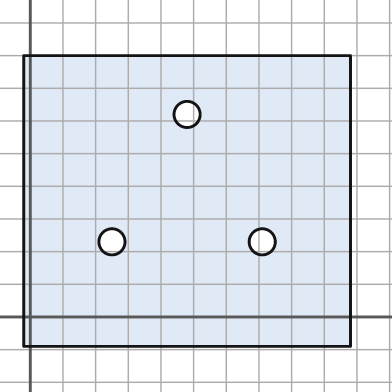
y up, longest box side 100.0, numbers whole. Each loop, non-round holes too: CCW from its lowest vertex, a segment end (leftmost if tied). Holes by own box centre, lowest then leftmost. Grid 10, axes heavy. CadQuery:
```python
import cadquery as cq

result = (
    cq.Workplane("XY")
    .moveTo(-2.0, -9.0)
    .lineTo(98.0, -9.0)
    .lineTo(98.0, 80.0)
    .lineTo(-2.0, 80.0)
    .close()
    .moveTo(25.0, 23.0)
    .circle(4.0)
    .moveTo(71.0, 23.0)
    .circle(4.0)
    .moveTo(48.0, 62.0)
    .circle(4.0)
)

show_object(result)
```